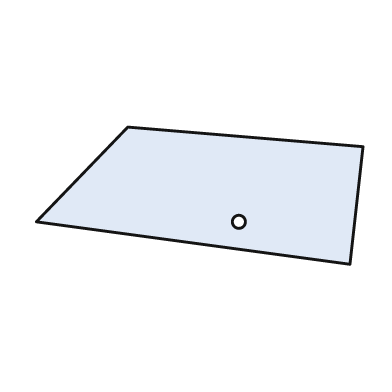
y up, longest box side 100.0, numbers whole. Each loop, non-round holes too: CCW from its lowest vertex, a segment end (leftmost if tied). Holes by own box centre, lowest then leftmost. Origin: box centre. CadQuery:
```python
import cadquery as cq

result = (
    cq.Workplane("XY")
    .moveTo(46.0, -21.0)
    .lineTo(50.0, 15.0)
    .lineTo(-22.0, 21.0)
    .lineTo(-50.0, -8.0)
    .close()
    .moveTo(12.0, -8.0)
    .circle(2.0)
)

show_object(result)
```